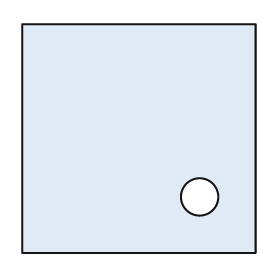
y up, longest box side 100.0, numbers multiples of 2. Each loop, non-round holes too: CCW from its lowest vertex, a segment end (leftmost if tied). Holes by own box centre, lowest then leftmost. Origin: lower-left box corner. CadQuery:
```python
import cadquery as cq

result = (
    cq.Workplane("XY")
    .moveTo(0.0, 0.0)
    .lineTo(100.0, 0.0)
    .lineTo(100.0, 98.0)
    .lineTo(0.0, 98.0)
    .close()
    .moveTo(76.0, 24.0)
    .circle(8.0)
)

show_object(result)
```